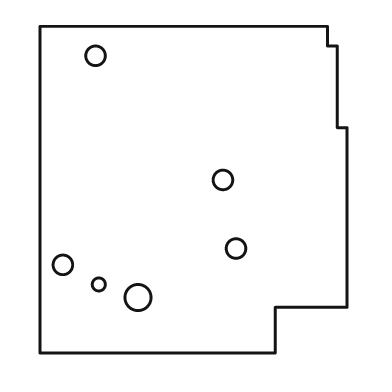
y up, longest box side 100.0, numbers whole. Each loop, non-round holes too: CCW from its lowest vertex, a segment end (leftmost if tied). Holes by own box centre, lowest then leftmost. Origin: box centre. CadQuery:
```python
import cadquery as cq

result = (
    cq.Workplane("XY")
    .moveTo(-47.0, -50.0)
    .lineTo(25.0, -50.0)
    .lineTo(25.0, -36.0)
    .lineTo(47.0, -36.0)
    .lineTo(47.0, 19.0)
    .lineTo(44.0, 19.0)
    .lineTo(44.0, 44.0)
    .lineTo(41.0, 44.0)
    .lineTo(41.0, 50.0)
    .lineTo(-47.0, 50.0)
    .close()
    .moveTo(-17.0, -33.0)
    .circle(4.0)
    .moveTo(-29.0, -29.0)
    .circle(2.0)
    .moveTo(-40.0, -23.0)
    .circle(3.0)
    .moveTo(13.0, -18.0)
    .circle(3.0)
    .moveTo(9.0, 3.0)
    .circle(3.0)
    .moveTo(-30.0, 41.0)
    .circle(3.0)
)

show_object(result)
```